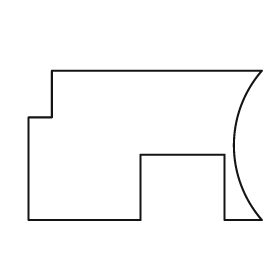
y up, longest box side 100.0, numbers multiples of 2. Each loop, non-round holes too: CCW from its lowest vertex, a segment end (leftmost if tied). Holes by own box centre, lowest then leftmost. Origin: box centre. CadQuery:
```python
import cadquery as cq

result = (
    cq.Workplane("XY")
    .moveTo(-50.0, -32.0)
    .lineTo(-2.0, -32.0)
    .lineTo(-2.0, -4.0)
    .lineTo(34.0, -4.0)
    .lineTo(34.0, -32.0)
    .lineTo(50.0, -32.0)
    .threePointArc((38.0, 0.0), (50.0, 32.0))
    .lineTo(-40.0, 32.0)
    .lineTo(-40.0, 12.0)
    .lineTo(-50.0, 12.0)
    .close()
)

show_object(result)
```